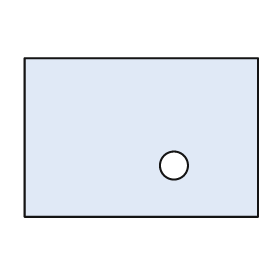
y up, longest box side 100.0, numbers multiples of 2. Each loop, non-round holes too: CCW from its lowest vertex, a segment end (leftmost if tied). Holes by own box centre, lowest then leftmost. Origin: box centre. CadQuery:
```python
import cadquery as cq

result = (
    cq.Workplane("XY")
    .moveTo(-50.0, -34.0)
    .lineTo(50.0, -34.0)
    .lineTo(50.0, 34.0)
    .lineTo(-50.0, 34.0)
    .close()
    .moveTo(14.0, -12.0)
    .circle(6.0)
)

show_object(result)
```